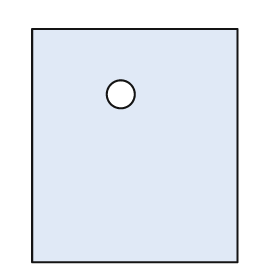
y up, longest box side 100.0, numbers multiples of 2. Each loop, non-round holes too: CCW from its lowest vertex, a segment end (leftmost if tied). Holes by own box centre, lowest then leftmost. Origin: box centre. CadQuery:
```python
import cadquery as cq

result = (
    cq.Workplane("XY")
    .moveTo(-44.0, -50.0)
    .lineTo(44.0, -50.0)
    .lineTo(44.0, 50.0)
    .lineTo(-44.0, 50.0)
    .close()
    .moveTo(-6.0, 22.0)
    .circle(6.0)
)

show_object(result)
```